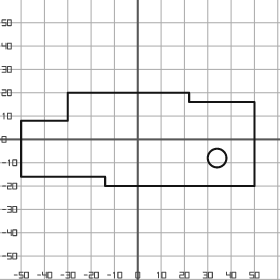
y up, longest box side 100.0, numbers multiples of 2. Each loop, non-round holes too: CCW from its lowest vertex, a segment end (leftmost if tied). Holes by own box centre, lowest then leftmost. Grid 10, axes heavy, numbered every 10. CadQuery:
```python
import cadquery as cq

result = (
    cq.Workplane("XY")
    .moveTo(-14.0, -20.0)
    .lineTo(50.0, -20.0)
    .lineTo(50.0, 16.0)
    .lineTo(22.0, 16.0)
    .lineTo(22.0, 20.0)
    .lineTo(-30.0, 20.0)
    .lineTo(-30.0, 8.0)
    .lineTo(-50.0, 8.0)
    .lineTo(-50.0, -16.0)
    .lineTo(-14.0, -16.0)
    .close()
    .moveTo(34.0, -8.0)
    .circle(4.0)
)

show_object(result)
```